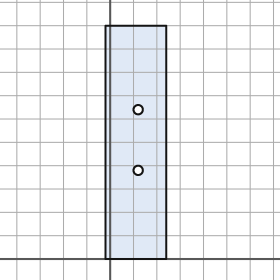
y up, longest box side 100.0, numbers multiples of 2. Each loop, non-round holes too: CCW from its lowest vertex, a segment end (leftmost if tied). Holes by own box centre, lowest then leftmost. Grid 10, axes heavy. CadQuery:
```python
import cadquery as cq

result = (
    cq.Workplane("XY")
    .moveTo(-2.0, 0.0)
    .lineTo(24.0, 0.0)
    .lineTo(24.0, 100.0)
    .lineTo(-2.0, 100.0)
    .close()
    .moveTo(12.0, 38.0)
    .circle(2.0)
    .moveTo(12.0, 64.0)
    .circle(2.0)
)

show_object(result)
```